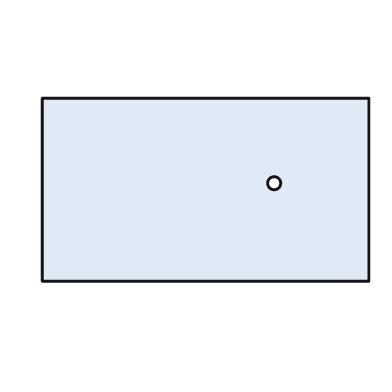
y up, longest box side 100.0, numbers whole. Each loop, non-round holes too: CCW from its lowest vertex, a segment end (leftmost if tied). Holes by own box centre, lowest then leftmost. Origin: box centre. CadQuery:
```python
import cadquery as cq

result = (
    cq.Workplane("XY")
    .moveTo(-50.0, -28.0)
    .lineTo(50.0, -28.0)
    .lineTo(50.0, 28.0)
    .lineTo(-50.0, 28.0)
    .close()
    .moveTo(21.0, 2.0)
    .circle(2.0)
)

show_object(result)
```